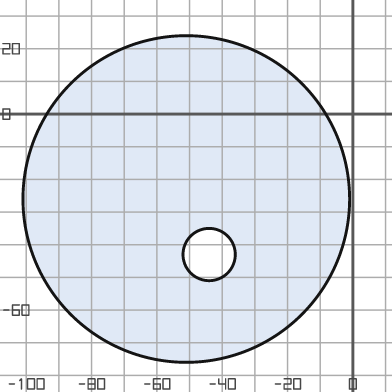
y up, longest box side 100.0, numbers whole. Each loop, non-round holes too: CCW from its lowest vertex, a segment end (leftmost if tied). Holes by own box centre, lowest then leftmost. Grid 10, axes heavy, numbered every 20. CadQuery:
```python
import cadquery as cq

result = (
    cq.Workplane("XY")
    .moveTo(-51.0, -26.0)
    .circle(50.0)
    .moveTo(-44.0, -43.0)
    .circle(8.0)
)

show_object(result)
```